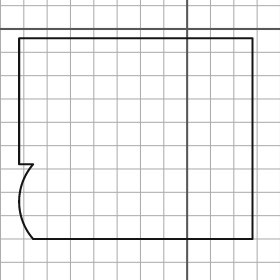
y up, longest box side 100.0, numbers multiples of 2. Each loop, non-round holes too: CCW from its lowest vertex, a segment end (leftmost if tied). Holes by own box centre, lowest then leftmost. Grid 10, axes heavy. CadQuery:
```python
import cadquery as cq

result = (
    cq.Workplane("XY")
    .moveTo(-66.0, -90.0)
    .lineTo(28.0, -90.0)
    .lineTo(28.0, -4.0)
    .lineTo(-72.0, -4.0)
    .lineTo(-72.0, -58.0)
    .lineTo(-66.0, -58.0)
    .threePointArc((-72.0, -74.0), (-66.0, -90.0))
    .close()
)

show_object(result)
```